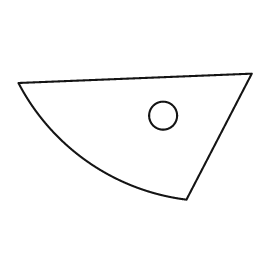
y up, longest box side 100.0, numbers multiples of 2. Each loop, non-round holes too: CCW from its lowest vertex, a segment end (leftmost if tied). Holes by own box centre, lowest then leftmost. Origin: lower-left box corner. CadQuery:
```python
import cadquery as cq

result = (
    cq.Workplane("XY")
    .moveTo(72.0, 0.0)
    .lineTo(100.0, 54.0)
    .lineTo(0.0, 50.0)
    .threePointArc((30.0, 16.0), (72.0, 0.0))
    .close()
    .moveTo(62.0, 36.0)
    .circle(6.0)
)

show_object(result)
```